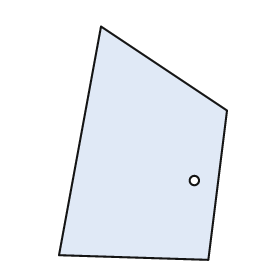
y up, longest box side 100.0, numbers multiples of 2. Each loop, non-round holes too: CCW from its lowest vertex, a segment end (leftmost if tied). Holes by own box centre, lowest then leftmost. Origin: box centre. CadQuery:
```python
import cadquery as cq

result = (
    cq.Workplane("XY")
    .moveTo(28.0, -50.0)
    .lineTo(36.0, 14.0)
    .lineTo(-18.0, 50.0)
    .lineTo(-36.0, -48.0)
    .close()
    .moveTo(22.0, -16.0)
    .circle(2.0)
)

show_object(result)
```